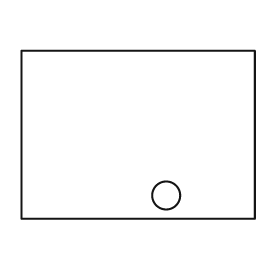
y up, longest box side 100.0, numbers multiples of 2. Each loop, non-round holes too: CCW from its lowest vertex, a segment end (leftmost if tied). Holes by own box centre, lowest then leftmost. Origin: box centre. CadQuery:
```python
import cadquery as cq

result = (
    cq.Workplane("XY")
    .moveTo(-50.0, -36.0)
    .lineTo(50.0, -36.0)
    .lineTo(50.0, 36.0)
    .lineTo(-50.0, 36.0)
    .close()
    .moveTo(12.0, -26.0)
    .circle(6.0)
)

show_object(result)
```